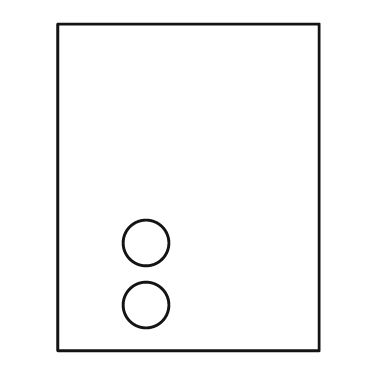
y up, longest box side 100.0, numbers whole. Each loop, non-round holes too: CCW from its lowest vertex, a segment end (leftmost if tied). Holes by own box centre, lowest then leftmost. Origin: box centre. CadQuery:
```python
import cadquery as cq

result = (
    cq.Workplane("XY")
    .moveTo(-40.0, -50.0)
    .lineTo(40.0, -50.0)
    .lineTo(40.0, 50.0)
    .lineTo(-40.0, 50.0)
    .close()
    .moveTo(-13.0, -36.0)
    .circle(7.0)
    .moveTo(-13.0, -17.0)
    .circle(7.0)
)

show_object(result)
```